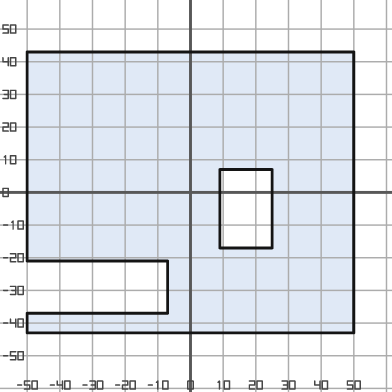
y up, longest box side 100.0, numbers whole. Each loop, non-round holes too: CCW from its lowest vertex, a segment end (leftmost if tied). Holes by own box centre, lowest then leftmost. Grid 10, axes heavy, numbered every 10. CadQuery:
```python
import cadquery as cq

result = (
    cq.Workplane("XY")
    .moveTo(-50.0, -43.0)
    .lineTo(50.0, -43.0)
    .lineTo(50.0, 43.0)
    .lineTo(-50.0, 43.0)
    .lineTo(-50.0, -21.0)
    .lineTo(-7.0, -21.0)
    .lineTo(-7.0, -37.0)
    .lineTo(-50.0, -37.0)
    .close()
    .moveTo(9.0, -17.0)
    .lineTo(25.0, -17.0)
    .lineTo(25.0, 7.0)
    .lineTo(9.0, 7.0)
    .close()
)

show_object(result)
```